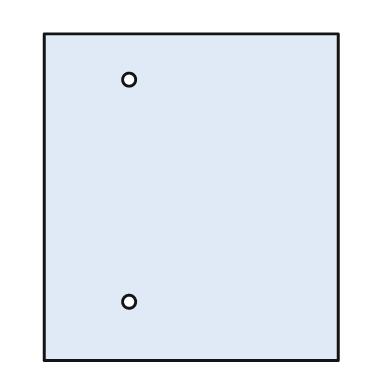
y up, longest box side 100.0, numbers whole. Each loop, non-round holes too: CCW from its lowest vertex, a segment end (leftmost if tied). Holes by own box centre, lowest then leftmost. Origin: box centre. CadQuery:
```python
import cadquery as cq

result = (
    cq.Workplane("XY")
    .moveTo(-45.0, -50.0)
    .lineTo(45.0, -50.0)
    .lineTo(45.0, 50.0)
    .lineTo(-45.0, 50.0)
    .close()
    .moveTo(-19.0, -32.0)
    .circle(2.0)
    .moveTo(-19.0, 36.0)
    .circle(2.0)
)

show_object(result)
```